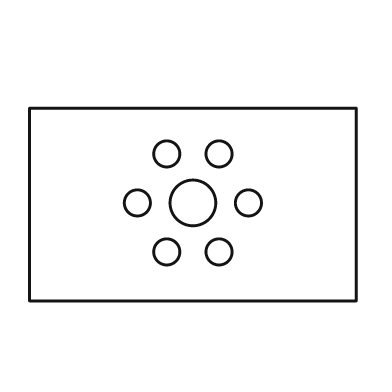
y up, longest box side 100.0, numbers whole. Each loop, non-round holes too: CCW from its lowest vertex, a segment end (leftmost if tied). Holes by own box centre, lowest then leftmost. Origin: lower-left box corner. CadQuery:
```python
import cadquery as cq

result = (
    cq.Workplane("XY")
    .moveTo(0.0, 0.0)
    .lineTo(100.0, 0.0)
    .lineTo(100.0, 59.0)
    .lineTo(0.0, 59.0)
    .close()
    .moveTo(42.0, 15.0)
    .circle(4.0)
    .moveTo(58.0, 15.0)
    .circle(4.0)
    .moveTo(33.0, 30.0)
    .circle(4.0)
    .moveTo(50.0, 30.0)
    .circle(7.0)
    .moveTo(67.0, 30.0)
    .circle(4.0)
    .moveTo(42.0, 45.0)
    .circle(4.0)
    .moveTo(58.0, 45.0)
    .circle(4.0)
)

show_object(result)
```